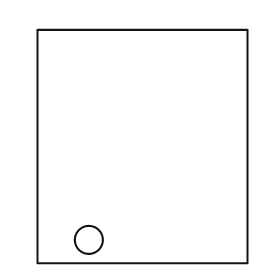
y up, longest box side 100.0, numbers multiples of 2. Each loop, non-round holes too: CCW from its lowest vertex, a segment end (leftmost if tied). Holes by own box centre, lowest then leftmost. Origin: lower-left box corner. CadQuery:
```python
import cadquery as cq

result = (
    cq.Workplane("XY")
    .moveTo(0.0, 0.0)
    .lineTo(90.0, 0.0)
    .lineTo(90.0, 100.0)
    .lineTo(0.0, 100.0)
    .close()
    .moveTo(22.0, 10.0)
    .circle(6.0)
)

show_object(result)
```